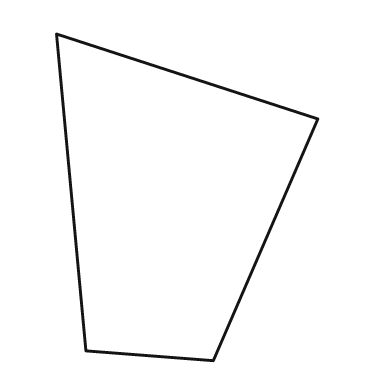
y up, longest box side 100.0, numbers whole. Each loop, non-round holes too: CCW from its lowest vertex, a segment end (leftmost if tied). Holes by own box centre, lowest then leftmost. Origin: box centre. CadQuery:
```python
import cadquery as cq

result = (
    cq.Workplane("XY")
    .moveTo(8.0, -50.0)
    .lineTo(40.0, 24.0)
    .lineTo(-40.0, 50.0)
    .lineTo(-31.0, -47.0)
    .close()
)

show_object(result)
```